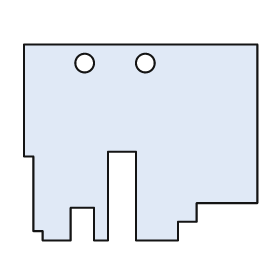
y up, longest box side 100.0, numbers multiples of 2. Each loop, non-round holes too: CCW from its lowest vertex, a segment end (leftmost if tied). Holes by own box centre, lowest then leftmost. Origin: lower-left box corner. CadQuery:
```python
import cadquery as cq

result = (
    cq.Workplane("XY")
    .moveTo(8.0, 0.0)
    .lineTo(20.0, 0.0)
    .lineTo(20.0, 14.0)
    .lineTo(30.0, 14.0)
    .lineTo(30.0, 0.0)
    .lineTo(36.0, 0.0)
    .lineTo(36.0, 38.0)
    .lineTo(48.0, 38.0)
    .lineTo(48.0, 0.0)
    .lineTo(66.0, 0.0)
    .lineTo(66.0, 8.0)
    .lineTo(74.0, 8.0)
    .lineTo(74.0, 16.0)
    .lineTo(100.0, 16.0)
    .lineTo(100.0, 84.0)
    .lineTo(0.0, 84.0)
    .lineTo(0.0, 36.0)
    .lineTo(4.0, 36.0)
    .lineTo(4.0, 4.0)
    .lineTo(8.0, 4.0)
    .close()
    .moveTo(26.0, 76.0)
    .circle(4.0)
    .moveTo(52.0, 76.0)
    .circle(4.0)
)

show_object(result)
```